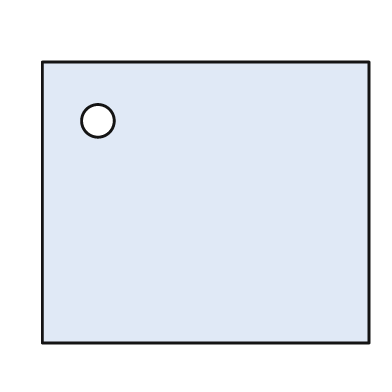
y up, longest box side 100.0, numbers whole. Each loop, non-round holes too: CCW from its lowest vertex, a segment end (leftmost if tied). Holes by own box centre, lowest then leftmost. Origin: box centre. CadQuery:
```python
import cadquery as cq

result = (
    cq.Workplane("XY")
    .moveTo(-50.0, -43.0)
    .lineTo(50.0, -43.0)
    .lineTo(50.0, 43.0)
    .lineTo(-50.0, 43.0)
    .close()
    .moveTo(-33.0, 25.0)
    .circle(5.0)
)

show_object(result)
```